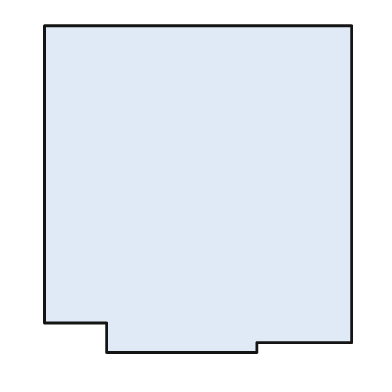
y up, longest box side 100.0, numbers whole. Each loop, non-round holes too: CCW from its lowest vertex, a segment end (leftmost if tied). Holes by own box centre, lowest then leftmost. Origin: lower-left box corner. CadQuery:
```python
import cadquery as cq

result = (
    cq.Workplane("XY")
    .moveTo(19.0, 0.0)
    .lineTo(65.0, 0.0)
    .lineTo(65.0, 3.0)
    .lineTo(94.0, 3.0)
    .lineTo(94.0, 100.0)
    .lineTo(0.0, 100.0)
    .lineTo(0.0, 9.0)
    .lineTo(19.0, 9.0)
    .close()
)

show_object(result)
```